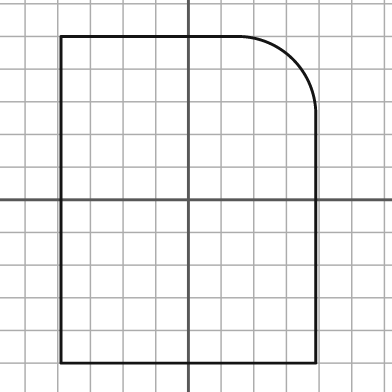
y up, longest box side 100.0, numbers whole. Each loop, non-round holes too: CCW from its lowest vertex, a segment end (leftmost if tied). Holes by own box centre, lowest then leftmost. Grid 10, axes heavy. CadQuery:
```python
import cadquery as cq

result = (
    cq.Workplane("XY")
    .moveTo(-39.0, -50.0)
    .lineTo(39.0, -50.0)
    .lineTo(39.0, 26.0)
    .threePointArc((32.0, 43.0), (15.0, 50.0))
    .lineTo(-39.0, 50.0)
    .close()
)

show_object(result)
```